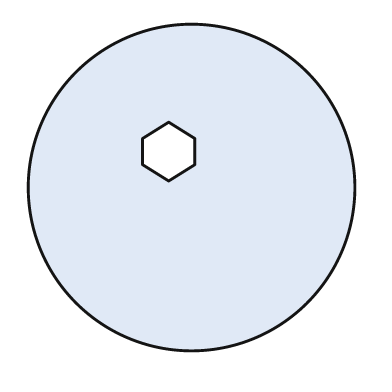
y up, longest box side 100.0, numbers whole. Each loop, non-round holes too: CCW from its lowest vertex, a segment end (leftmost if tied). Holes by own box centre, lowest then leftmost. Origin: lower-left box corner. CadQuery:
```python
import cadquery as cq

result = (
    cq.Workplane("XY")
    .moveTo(50.0, 50.0)
    .circle(50.0)
    .moveTo(43.0, 52.0)
    .lineTo(51.0, 57.0)
    .lineTo(51.0, 65.0)
    .lineTo(43.0, 70.0)
    .lineTo(35.0, 65.0)
    .lineTo(35.0, 57.0)
    .close()
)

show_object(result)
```